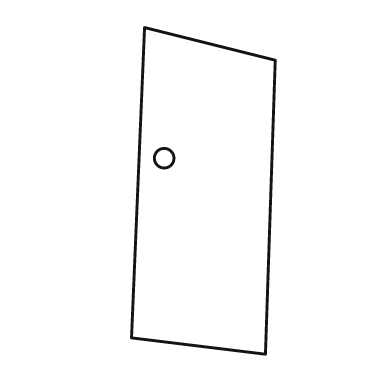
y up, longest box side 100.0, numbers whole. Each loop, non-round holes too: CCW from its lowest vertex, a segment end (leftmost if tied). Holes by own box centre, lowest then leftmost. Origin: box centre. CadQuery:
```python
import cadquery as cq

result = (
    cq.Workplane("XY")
    .moveTo(19.0, -50.0)
    .lineTo(22.0, 40.0)
    .lineTo(-18.0, 50.0)
    .lineTo(-22.0, -45.0)
    .close()
    .moveTo(-12.0, 10.0)
    .circle(3.0)
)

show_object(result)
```